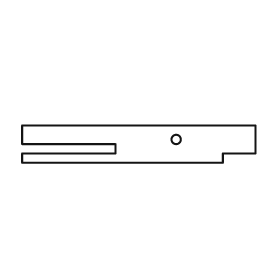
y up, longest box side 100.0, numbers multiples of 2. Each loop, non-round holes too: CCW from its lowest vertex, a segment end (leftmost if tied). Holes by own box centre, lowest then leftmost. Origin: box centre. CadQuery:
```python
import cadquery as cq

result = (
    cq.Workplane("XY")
    .moveTo(-50.0, -8.0)
    .lineTo(36.0, -8.0)
    .lineTo(36.0, -4.0)
    .lineTo(50.0, -4.0)
    .lineTo(50.0, 8.0)
    .lineTo(-50.0, 8.0)
    .lineTo(-50.0, 0.0)
    .lineTo(-10.0, 0.0)
    .lineTo(-10.0, -4.0)
    .lineTo(-50.0, -4.0)
    .close()
    .moveTo(16.0, 2.0)
    .circle(2.0)
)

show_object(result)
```